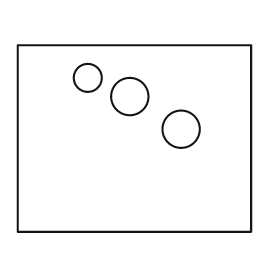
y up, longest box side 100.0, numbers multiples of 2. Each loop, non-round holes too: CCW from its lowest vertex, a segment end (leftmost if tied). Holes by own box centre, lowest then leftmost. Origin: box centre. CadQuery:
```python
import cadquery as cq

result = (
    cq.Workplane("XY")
    .moveTo(-50.0, -40.0)
    .lineTo(50.0, -40.0)
    .lineTo(50.0, 40.0)
    .lineTo(-50.0, 40.0)
    .close()
    .moveTo(20.0, 4.0)
    .circle(8.0)
    .moveTo(-2.0, 18.0)
    .circle(8.0)
    .moveTo(-20.0, 26.0)
    .circle(6.0)
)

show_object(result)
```